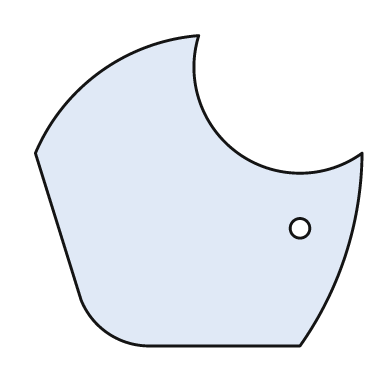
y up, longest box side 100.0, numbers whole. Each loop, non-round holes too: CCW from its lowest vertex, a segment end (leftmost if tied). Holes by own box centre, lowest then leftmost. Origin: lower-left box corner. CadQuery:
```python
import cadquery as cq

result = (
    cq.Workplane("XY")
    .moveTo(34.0, 0.0)
    .lineTo(81.0, 0.0)
    .threePointArc((95.0, 28.0), (100.0, 59.0))
    .threePointArc((62.0, 59.0), (50.0, 95.0))
    .threePointArc((20.0, 84.0), (0.0, 59.0))
    .lineTo(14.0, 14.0)
    .threePointArc((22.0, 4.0), (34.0, 0.0))
    .close()
    .moveTo(81.0, 36.0)
    .circle(3.0)
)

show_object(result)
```